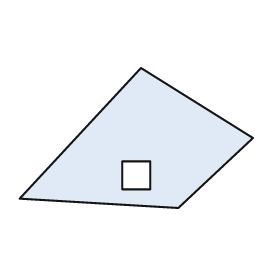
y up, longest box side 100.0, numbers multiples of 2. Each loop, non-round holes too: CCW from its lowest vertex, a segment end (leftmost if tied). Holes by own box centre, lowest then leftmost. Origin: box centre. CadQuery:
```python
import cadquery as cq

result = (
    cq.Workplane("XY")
    .moveTo(18.0, -30.0)
    .lineTo(50.0, 0.0)
    .lineTo(2.0, 30.0)
    .lineTo(-50.0, -26.0)
    .close()
    .moveTo(-6.0, -22.0)
    .lineTo(6.0, -22.0)
    .lineTo(6.0, -10.0)
    .lineTo(-6.0, -10.0)
    .close()
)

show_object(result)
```